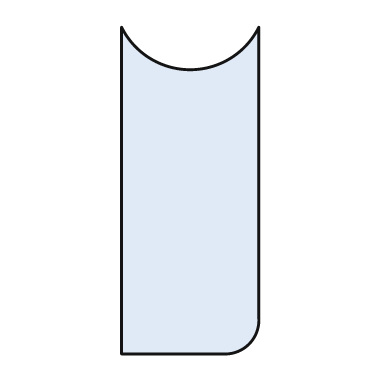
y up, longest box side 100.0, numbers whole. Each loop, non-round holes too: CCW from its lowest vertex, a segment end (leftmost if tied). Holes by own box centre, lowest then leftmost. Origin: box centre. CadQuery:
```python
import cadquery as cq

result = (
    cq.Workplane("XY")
    .moveTo(-21.0, -50.0)
    .lineTo(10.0, -50.0)
    .threePointArc((18.0, -47.0), (21.0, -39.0))
    .lineTo(21.0, 50.0)
    .threePointArc((0.0, 37.0), (-21.0, 50.0))
    .close()
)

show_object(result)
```